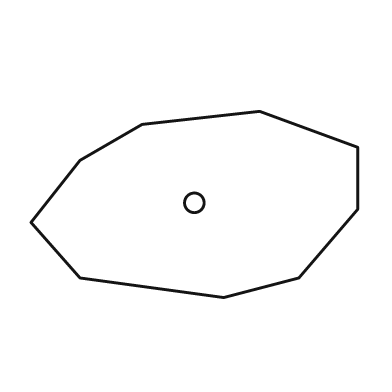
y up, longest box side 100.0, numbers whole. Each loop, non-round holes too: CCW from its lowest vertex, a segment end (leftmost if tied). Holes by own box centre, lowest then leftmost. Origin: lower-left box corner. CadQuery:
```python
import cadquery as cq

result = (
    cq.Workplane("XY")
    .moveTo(59.0, 0.0)
    .lineTo(82.0, 6.0)
    .lineTo(100.0, 27.0)
    .lineTo(100.0, 46.0)
    .lineTo(70.0, 57.0)
    .lineTo(34.0, 53.0)
    .lineTo(15.0, 42.0)
    .lineTo(0.0, 23.0)
    .lineTo(15.0, 6.0)
    .close()
    .moveTo(50.0, 29.0)
    .circle(3.0)
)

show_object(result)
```